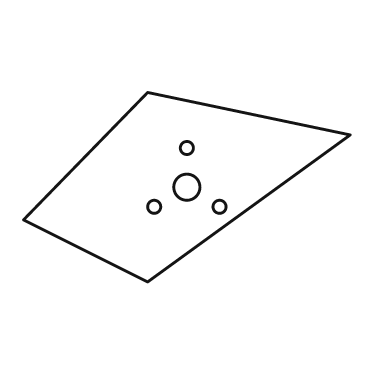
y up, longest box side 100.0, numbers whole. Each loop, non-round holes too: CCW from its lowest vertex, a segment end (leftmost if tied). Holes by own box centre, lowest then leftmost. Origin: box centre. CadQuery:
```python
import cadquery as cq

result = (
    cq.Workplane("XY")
    .moveTo(-12.0, -29.0)
    .lineTo(50.0, 16.0)
    .lineTo(-12.0, 29.0)
    .lineTo(-50.0, -10.0)
    .close()
    .moveTo(-10.0, -6.0)
    .circle(2.0)
    .moveTo(10.0, -6.0)
    .circle(2.0)
    .moveTo(0.0, 0.0)
    .circle(4.0)
    .moveTo(0.0, 12.0)
    .circle(2.0)
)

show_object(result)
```